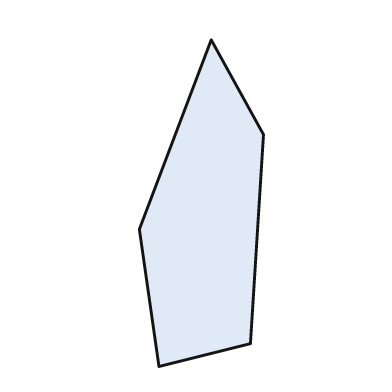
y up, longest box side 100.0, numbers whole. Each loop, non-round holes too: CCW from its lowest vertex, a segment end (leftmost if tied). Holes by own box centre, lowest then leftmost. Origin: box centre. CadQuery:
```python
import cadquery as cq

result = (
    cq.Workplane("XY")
    .moveTo(-13.0, -50.0)
    .lineTo(15.0, -43.0)
    .lineTo(19.0, 21.0)
    .lineTo(3.0, 50.0)
    .lineTo(-19.0, -8.0)
    .close()
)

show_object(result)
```